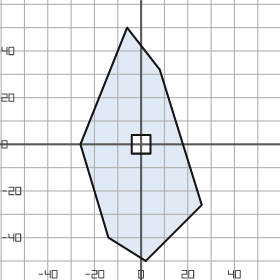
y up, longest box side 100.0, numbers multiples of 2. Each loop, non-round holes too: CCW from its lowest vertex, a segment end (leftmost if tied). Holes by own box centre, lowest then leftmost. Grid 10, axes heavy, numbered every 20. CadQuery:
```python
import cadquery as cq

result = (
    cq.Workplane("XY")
    .moveTo(2.0, -50.0)
    .lineTo(26.0, -26.0)
    .lineTo(8.0, 32.0)
    .lineTo(-6.0, 50.0)
    .lineTo(-26.0, 0.0)
    .lineTo(-14.0, -40.0)
    .close()
    .moveTo(-4.0, -4.0)
    .lineTo(4.0, -4.0)
    .lineTo(4.0, 4.0)
    .lineTo(-4.0, 4.0)
    .close()
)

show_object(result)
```